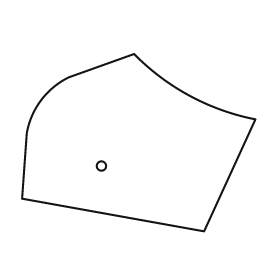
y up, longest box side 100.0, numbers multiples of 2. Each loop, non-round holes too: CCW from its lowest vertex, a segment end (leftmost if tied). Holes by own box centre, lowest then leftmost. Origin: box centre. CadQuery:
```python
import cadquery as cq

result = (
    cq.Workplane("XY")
    .moveTo(28.0, -38.0)
    .lineTo(50.0, 10.0)
    .threePointArc((22.0, 20.0), (-2.0, 38.0))
    .lineTo(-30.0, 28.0)
    .threePointArc((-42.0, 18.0), (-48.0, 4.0))
    .lineTo(-50.0, -24.0)
    .close()
    .moveTo(-16.0, -10.0)
    .circle(2.0)
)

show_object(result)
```